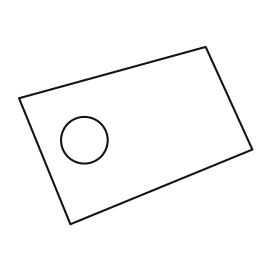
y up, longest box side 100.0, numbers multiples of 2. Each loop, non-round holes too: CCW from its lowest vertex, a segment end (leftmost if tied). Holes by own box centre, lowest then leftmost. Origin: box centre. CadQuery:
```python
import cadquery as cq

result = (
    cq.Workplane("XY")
    .moveTo(-28.0, -38.0)
    .lineTo(50.0, -6.0)
    .lineTo(30.0, 38.0)
    .lineTo(-50.0, 16.0)
    .close()
    .moveTo(-22.0, -2.0)
    .circle(10.0)
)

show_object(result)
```